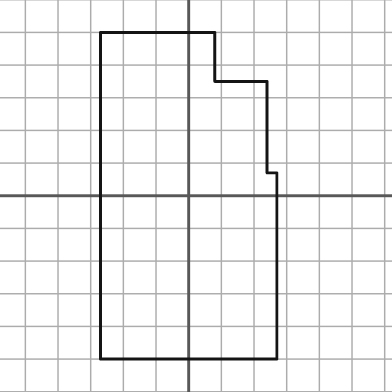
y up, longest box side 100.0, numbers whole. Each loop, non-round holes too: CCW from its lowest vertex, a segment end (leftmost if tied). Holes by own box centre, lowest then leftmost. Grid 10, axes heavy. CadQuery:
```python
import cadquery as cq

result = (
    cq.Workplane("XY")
    .moveTo(-27.0, -50.0)
    .lineTo(27.0, -50.0)
    .lineTo(27.0, 7.0)
    .lineTo(24.0, 7.0)
    .lineTo(24.0, 35.0)
    .lineTo(8.0, 35.0)
    .lineTo(8.0, 50.0)
    .lineTo(-27.0, 50.0)
    .close()
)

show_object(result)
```